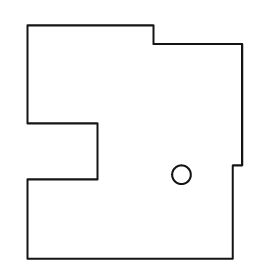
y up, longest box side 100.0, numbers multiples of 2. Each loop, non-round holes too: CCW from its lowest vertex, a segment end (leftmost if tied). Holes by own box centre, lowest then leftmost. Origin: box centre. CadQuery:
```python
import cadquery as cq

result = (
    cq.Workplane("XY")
    .moveTo(-46.0, -50.0)
    .lineTo(42.0, -50.0)
    .lineTo(42.0, -10.0)
    .lineTo(46.0, -10.0)
    .lineTo(46.0, 42.0)
    .lineTo(8.0, 42.0)
    .lineTo(8.0, 50.0)
    .lineTo(-46.0, 50.0)
    .lineTo(-46.0, 8.0)
    .lineTo(-16.0, 8.0)
    .lineTo(-16.0, -16.0)
    .lineTo(-46.0, -16.0)
    .close()
    .moveTo(20.0, -14.0)
    .circle(4.0)
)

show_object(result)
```